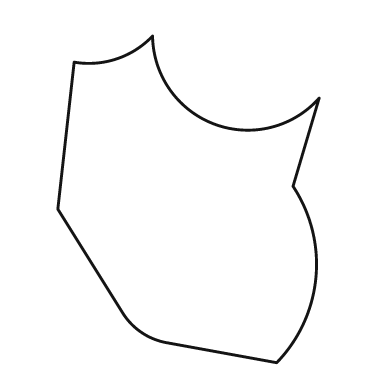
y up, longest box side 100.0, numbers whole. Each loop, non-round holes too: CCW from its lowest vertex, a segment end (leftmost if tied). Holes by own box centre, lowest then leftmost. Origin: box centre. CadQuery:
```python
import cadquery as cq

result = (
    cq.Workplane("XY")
    .moveTo(27.0, -50.0)
    .threePointArc((39.0, -24.0), (32.0, 4.0))
    .lineTo(40.0, 31.0)
    .threePointArc((8.0, 23.0), (-11.0, 50.0))
    .threePointArc((-22.0, 43.0), (-35.0, 42.0))
    .lineTo(-40.0, -3.0)
    .lineTo(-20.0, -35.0)
    .threePointArc((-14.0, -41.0), (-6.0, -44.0))
    .close()
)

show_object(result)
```